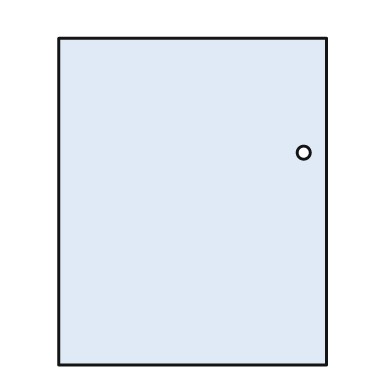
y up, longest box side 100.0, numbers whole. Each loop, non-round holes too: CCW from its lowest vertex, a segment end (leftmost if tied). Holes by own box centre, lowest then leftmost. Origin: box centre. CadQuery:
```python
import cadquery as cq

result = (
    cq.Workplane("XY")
    .moveTo(-41.0, -50.0)
    .lineTo(41.0, -50.0)
    .lineTo(41.0, 50.0)
    .lineTo(-41.0, 50.0)
    .close()
    .moveTo(34.0, 15.0)
    .circle(2.0)
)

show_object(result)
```